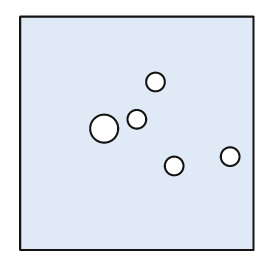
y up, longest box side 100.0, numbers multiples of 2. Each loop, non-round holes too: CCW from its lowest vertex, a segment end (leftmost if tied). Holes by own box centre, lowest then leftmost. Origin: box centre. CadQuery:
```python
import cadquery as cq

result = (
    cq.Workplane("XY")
    .moveTo(-50.0, -50.0)
    .lineTo(50.0, -50.0)
    .lineTo(50.0, 50.0)
    .lineTo(-50.0, 50.0)
    .close()
    .moveTo(16.0, -14.0)
    .circle(4.0)
    .moveTo(40.0, -10.0)
    .circle(4.0)
    .moveTo(-14.0, 2.0)
    .circle(6.0)
    .moveTo(0.0, 6.0)
    .circle(4.0)
    .moveTo(8.0, 22.0)
    .circle(4.0)
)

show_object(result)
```